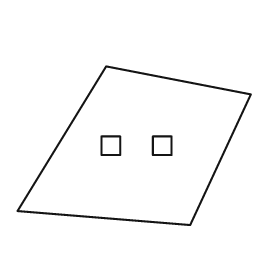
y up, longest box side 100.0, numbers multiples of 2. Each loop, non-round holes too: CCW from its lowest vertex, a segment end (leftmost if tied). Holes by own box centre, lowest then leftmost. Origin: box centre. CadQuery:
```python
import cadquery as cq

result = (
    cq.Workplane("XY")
    .moveTo(24.0, -34.0)
    .lineTo(50.0, 22.0)
    .lineTo(-12.0, 34.0)
    .lineTo(-50.0, -28.0)
    .close()
    .moveTo(-14.0, -4.0)
    .lineTo(-6.0, -4.0)
    .lineTo(-6.0, 4.0)
    .lineTo(-14.0, 4.0)
    .close()
    .moveTo(8.0, -4.0)
    .lineTo(16.0, -4.0)
    .lineTo(16.0, 4.0)
    .lineTo(8.0, 4.0)
    .close()
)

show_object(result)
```